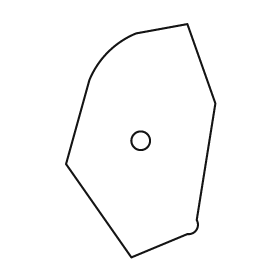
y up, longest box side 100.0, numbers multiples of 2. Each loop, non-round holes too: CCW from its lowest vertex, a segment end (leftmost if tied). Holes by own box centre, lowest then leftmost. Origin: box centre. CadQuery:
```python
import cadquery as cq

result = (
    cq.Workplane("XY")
    .moveTo(-4.0, -50.0)
    .lineTo(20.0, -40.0)
    .threePointArc((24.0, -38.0), (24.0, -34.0))
    .lineTo(32.0, 16.0)
    .lineTo(20.0, 50.0)
    .lineTo(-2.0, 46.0)
    .threePointArc((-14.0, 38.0), (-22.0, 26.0))
    .lineTo(-32.0, -10.0)
    .close()
    .moveTo(0.0, 0.0)
    .circle(4.0)
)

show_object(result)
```